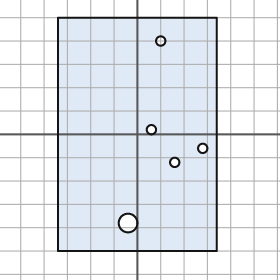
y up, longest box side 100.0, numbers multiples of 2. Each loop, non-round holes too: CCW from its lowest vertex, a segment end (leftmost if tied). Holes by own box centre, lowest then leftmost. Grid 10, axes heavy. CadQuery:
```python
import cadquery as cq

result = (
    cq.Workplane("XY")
    .moveTo(-34.0, -50.0)
    .lineTo(34.0, -50.0)
    .lineTo(34.0, 50.0)
    .lineTo(-34.0, 50.0)
    .close()
    .moveTo(-4.0, -38.0)
    .circle(4.0)
    .moveTo(16.0, -12.0)
    .circle(2.0)
    .moveTo(28.0, -6.0)
    .circle(2.0)
    .moveTo(6.0, 2.0)
    .circle(2.0)
    .moveTo(10.0, 40.0)
    .circle(2.0)
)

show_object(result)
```